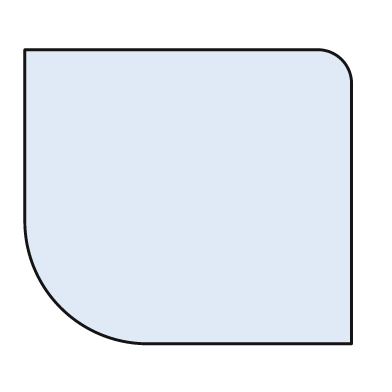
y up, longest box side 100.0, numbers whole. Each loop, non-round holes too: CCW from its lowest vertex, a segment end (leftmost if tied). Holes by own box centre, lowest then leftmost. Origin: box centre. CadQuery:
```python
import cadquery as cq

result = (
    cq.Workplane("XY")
    .moveTo(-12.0, -45.0)
    .lineTo(50.0, -45.0)
    .lineTo(50.0, 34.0)
    .threePointArc((47.0, 42.0), (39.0, 45.0))
    .lineTo(-50.0, 45.0)
    .lineTo(-50.0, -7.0)
    .threePointArc((-39.0, -34.0), (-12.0, -45.0))
    .close()
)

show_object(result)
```